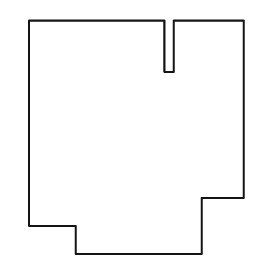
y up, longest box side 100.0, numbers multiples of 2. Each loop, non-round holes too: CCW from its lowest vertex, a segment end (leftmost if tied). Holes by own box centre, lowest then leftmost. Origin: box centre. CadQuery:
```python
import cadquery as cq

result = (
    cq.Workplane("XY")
    .moveTo(-26.0, -50.0)
    .lineTo(28.0, -50.0)
    .lineTo(28.0, -26.0)
    .lineTo(46.0, -26.0)
    .lineTo(46.0, 50.0)
    .lineTo(16.0, 50.0)
    .lineTo(16.0, 28.0)
    .lineTo(12.0, 28.0)
    .lineTo(12.0, 50.0)
    .lineTo(-46.0, 50.0)
    .lineTo(-46.0, -38.0)
    .lineTo(-26.0, -38.0)
    .close()
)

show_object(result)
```